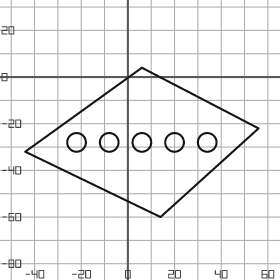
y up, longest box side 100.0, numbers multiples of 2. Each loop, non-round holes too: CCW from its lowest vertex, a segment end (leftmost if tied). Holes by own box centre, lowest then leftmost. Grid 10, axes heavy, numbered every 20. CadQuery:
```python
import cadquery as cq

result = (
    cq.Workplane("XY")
    .moveTo(14.0, -60.0)
    .lineTo(56.0, -22.0)
    .lineTo(6.0, 4.0)
    .lineTo(-44.0, -32.0)
    .close()
    .moveTo(-22.0, -28.0)
    .circle(4.0)
    .moveTo(-8.0, -28.0)
    .circle(4.0)
    .moveTo(6.0, -28.0)
    .circle(4.0)
    .moveTo(20.0, -28.0)
    .circle(4.0)
    .moveTo(34.0, -28.0)
    .circle(4.0)
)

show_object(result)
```